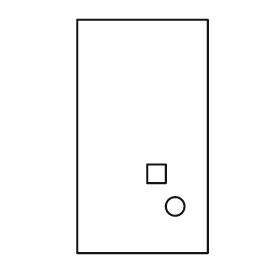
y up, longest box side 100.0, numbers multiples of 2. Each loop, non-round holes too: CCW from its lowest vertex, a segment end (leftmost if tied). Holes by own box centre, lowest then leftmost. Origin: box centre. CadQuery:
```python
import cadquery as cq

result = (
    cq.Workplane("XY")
    .moveTo(-28.0, -50.0)
    .lineTo(28.0, -50.0)
    .lineTo(28.0, 50.0)
    .lineTo(-28.0, 50.0)
    .close()
    .moveTo(14.0, -30.0)
    .circle(4.0)
    .moveTo(2.0, -20.0)
    .lineTo(10.0, -20.0)
    .lineTo(10.0, -12.0)
    .lineTo(2.0, -12.0)
    .close()
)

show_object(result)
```